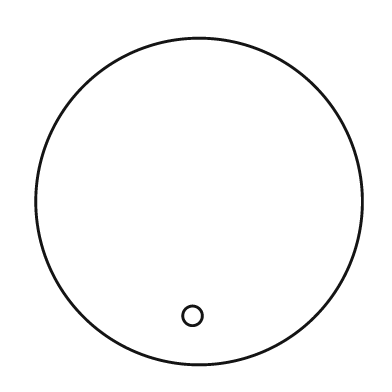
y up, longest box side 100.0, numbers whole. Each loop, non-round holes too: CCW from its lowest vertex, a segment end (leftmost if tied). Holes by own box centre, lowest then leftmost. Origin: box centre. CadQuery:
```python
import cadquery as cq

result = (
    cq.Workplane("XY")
    .moveTo(0.0, 0.0)
    .circle(50.0)
    .moveTo(-2.0, -35.0)
    .circle(3.0)
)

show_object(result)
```